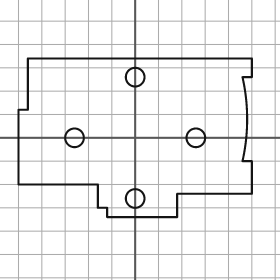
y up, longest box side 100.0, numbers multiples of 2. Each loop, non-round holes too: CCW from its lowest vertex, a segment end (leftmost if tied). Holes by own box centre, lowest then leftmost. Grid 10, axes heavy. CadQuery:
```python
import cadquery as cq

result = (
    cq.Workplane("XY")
    .moveTo(-12.0, -34.0)
    .lineTo(18.0, -34.0)
    .lineTo(18.0, -24.0)
    .lineTo(50.0, -24.0)
    .lineTo(50.0, -10.0)
    .lineTo(46.0, -10.0)
    .threePointArc((48.0, 8.0), (46.0, 26.0))
    .lineTo(50.0, 26.0)
    .lineTo(50.0, 34.0)
    .lineTo(-46.0, 34.0)
    .lineTo(-46.0, 12.0)
    .lineTo(-50.0, 12.0)
    .lineTo(-50.0, -20.0)
    .lineTo(-16.0, -20.0)
    .lineTo(-16.0, -30.0)
    .lineTo(-12.0, -30.0)
    .close()
    .moveTo(0.0, -26.0)
    .circle(4.0)
    .moveTo(-26.0, 0.0)
    .circle(4.0)
    .moveTo(26.0, 0.0)
    .circle(4.0)
    .moveTo(0.0, 26.0)
    .circle(4.0)
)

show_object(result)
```